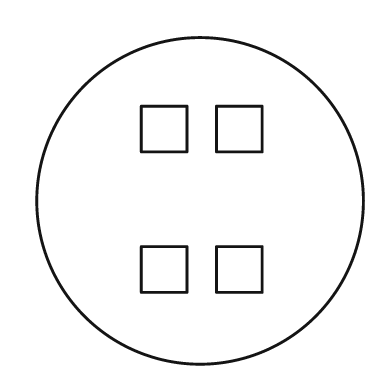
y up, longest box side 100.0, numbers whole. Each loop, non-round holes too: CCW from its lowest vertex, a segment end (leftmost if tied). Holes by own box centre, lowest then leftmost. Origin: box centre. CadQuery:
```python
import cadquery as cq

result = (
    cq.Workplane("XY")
    .moveTo(0.0, 0.0)
    .circle(50.0)
    .moveTo(-18.0, -28.0)
    .lineTo(-4.0, -28.0)
    .lineTo(-4.0, -14.0)
    .lineTo(-18.0, -14.0)
    .close()
    .moveTo(5.0, -28.0)
    .lineTo(19.0, -28.0)
    .lineTo(19.0, -14.0)
    .lineTo(5.0, -14.0)
    .close()
    .moveTo(-18.0, 15.0)
    .lineTo(-4.0, 15.0)
    .lineTo(-4.0, 29.0)
    .lineTo(-18.0, 29.0)
    .close()
    .moveTo(5.0, 15.0)
    .lineTo(19.0, 15.0)
    .lineTo(19.0, 29.0)
    .lineTo(5.0, 29.0)
    .close()
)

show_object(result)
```